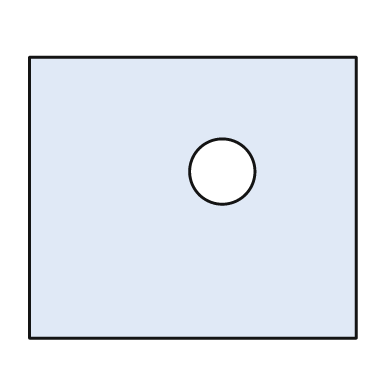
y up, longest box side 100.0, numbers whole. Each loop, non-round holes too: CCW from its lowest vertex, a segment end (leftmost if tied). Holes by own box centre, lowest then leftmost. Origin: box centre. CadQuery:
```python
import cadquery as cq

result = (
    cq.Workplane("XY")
    .moveTo(-50.0, -43.0)
    .lineTo(50.0, -43.0)
    .lineTo(50.0, 43.0)
    .lineTo(-50.0, 43.0)
    .close()
    .moveTo(9.0, 8.0)
    .circle(10.0)
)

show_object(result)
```